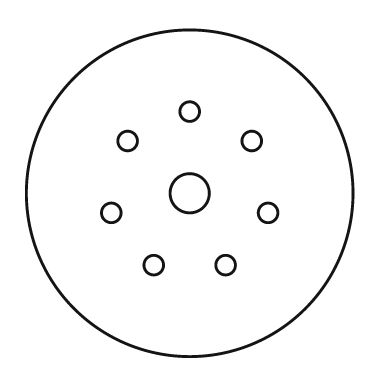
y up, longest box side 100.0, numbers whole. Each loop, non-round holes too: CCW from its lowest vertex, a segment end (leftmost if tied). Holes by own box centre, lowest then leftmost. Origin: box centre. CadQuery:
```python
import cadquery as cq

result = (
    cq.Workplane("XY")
    .moveTo(0.0, 0.0)
    .circle(50.0)
    .moveTo(-11.0, -22.0)
    .circle(3.0)
    .moveTo(11.0, -22.0)
    .circle(3.0)
    .moveTo(-24.0, -6.0)
    .circle(3.0)
    .moveTo(24.0, -6.0)
    .circle(3.0)
    .moveTo(0.0, 0.0)
    .circle(6.0)
    .moveTo(-19.0, 16.0)
    .circle(3.0)
    .moveTo(19.0, 16.0)
    .circle(3.0)
    .moveTo(0.0, 25.0)
    .circle(3.0)
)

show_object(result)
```